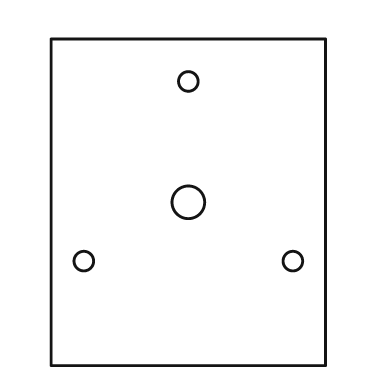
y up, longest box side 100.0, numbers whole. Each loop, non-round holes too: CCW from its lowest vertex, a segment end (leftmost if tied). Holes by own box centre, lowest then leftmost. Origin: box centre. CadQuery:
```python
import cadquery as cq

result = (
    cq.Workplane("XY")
    .moveTo(-42.0, -50.0)
    .lineTo(42.0, -50.0)
    .lineTo(42.0, 50.0)
    .lineTo(-42.0, 50.0)
    .close()
    .moveTo(-32.0, -18.0)
    .circle(3.0)
    .moveTo(32.0, -18.0)
    .circle(3.0)
    .moveTo(0.0, 0.0)
    .circle(5.0)
    .moveTo(0.0, 37.0)
    .circle(3.0)
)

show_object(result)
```